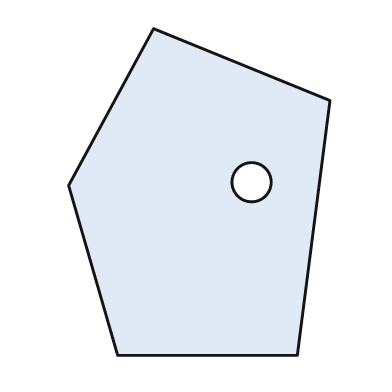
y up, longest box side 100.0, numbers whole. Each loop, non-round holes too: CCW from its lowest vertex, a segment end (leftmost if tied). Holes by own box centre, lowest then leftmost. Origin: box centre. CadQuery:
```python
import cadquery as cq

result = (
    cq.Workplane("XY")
    .moveTo(-25.0, -50.0)
    .lineTo(30.0, -50.0)
    .lineTo(40.0, 28.0)
    .lineTo(-14.0, 50.0)
    .lineTo(-40.0, 2.0)
    .close()
    .moveTo(16.0, 3.0)
    .circle(6.0)
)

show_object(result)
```